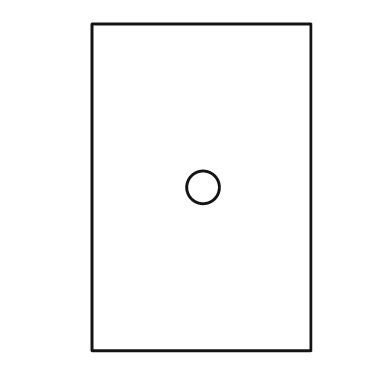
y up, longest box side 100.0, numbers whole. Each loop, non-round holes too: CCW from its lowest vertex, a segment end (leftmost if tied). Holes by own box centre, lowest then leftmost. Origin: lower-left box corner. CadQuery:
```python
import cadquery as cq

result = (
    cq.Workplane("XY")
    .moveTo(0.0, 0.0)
    .lineTo(67.0, 0.0)
    .lineTo(67.0, 100.0)
    .lineTo(0.0, 100.0)
    .close()
    .moveTo(34.0, 50.0)
    .circle(5.0)
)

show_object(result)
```